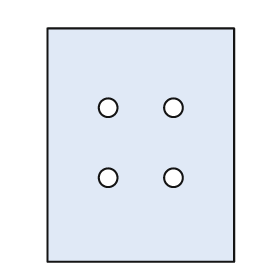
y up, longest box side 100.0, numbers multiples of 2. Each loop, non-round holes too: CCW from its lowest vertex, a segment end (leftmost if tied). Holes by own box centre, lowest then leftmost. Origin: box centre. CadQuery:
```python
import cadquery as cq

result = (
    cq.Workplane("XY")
    .moveTo(-40.0, -50.0)
    .lineTo(40.0, -50.0)
    .lineTo(40.0, 50.0)
    .lineTo(-40.0, 50.0)
    .close()
    .moveTo(-14.0, -14.0)
    .circle(4.0)
    .moveTo(14.0, -14.0)
    .circle(4.0)
    .moveTo(-14.0, 16.0)
    .circle(4.0)
    .moveTo(14.0, 16.0)
    .circle(4.0)
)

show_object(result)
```